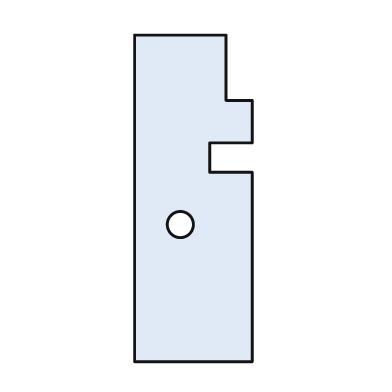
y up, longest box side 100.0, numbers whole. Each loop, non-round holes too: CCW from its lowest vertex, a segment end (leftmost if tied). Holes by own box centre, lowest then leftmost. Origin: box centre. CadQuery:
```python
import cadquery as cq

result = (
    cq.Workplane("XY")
    .moveTo(-18.0, -50.0)
    .lineTo(18.0, -50.0)
    .lineTo(18.0, 8.0)
    .lineTo(5.0, 8.0)
    .lineTo(5.0, 17.0)
    .lineTo(18.0, 17.0)
    .lineTo(18.0, 30.0)
    .lineTo(10.0, 30.0)
    .lineTo(10.0, 50.0)
    .lineTo(-18.0, 50.0)
    .close()
    .moveTo(-4.0, -8.0)
    .circle(4.0)
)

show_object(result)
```